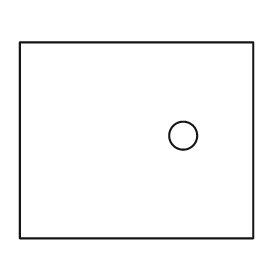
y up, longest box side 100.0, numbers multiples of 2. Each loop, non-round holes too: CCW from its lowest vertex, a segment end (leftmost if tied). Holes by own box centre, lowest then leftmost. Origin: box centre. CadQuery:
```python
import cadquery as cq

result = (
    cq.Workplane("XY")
    .moveTo(-50.0, -42.0)
    .lineTo(50.0, -42.0)
    .lineTo(50.0, 42.0)
    .lineTo(-50.0, 42.0)
    .close()
    .moveTo(20.0, 2.0)
    .circle(6.0)
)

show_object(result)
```